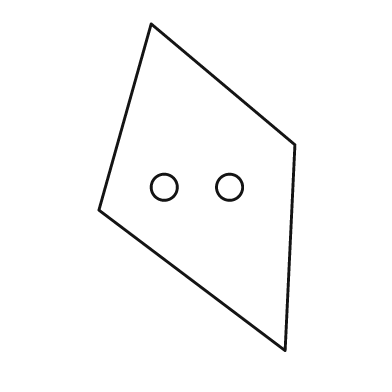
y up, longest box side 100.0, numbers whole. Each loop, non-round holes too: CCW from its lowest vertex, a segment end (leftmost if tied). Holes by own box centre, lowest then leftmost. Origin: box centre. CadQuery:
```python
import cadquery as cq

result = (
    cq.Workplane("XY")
    .moveTo(27.0, -50.0)
    .lineTo(30.0, 13.0)
    .lineTo(-14.0, 50.0)
    .lineTo(-30.0, -7.0)
    .close()
    .moveTo(-10.0, 0.0)
    .circle(4.0)
    .moveTo(10.0, 0.0)
    .circle(4.0)
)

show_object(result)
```